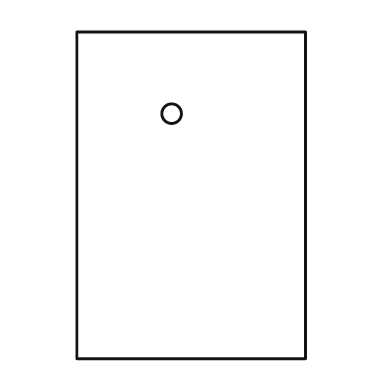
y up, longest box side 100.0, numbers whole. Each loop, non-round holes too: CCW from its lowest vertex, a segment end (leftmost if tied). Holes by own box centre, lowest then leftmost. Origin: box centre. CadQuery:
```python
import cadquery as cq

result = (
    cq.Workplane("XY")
    .moveTo(-35.0, -50.0)
    .lineTo(35.0, -50.0)
    .lineTo(35.0, 50.0)
    .lineTo(-35.0, 50.0)
    .close()
    .moveTo(-6.0, 25.0)
    .circle(3.0)
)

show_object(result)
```